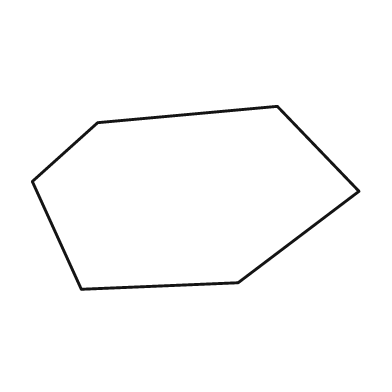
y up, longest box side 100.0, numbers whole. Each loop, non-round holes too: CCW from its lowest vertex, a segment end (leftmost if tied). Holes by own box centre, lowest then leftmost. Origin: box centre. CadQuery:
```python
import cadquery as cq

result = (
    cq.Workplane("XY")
    .moveTo(-35.0, -28.0)
    .lineTo(13.0, -26.0)
    .lineTo(50.0, 2.0)
    .lineTo(25.0, 28.0)
    .lineTo(-30.0, 23.0)
    .lineTo(-50.0, 5.0)
    .close()
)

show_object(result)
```